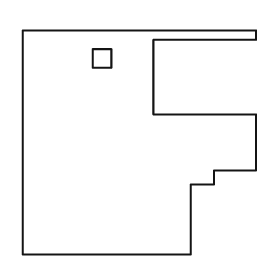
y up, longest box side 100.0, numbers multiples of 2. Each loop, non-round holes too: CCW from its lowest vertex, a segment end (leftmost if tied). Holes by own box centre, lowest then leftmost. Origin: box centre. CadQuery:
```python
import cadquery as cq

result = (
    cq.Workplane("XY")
    .moveTo(-50.0, -48.0)
    .lineTo(22.0, -48.0)
    .lineTo(22.0, -18.0)
    .lineTo(32.0, -18.0)
    .lineTo(32.0, -12.0)
    .lineTo(50.0, -12.0)
    .lineTo(50.0, 12.0)
    .lineTo(6.0, 12.0)
    .lineTo(6.0, 44.0)
    .lineTo(50.0, 44.0)
    .lineTo(50.0, 48.0)
    .lineTo(-50.0, 48.0)
    .close()
    .moveTo(-20.0, 32.0)
    .lineTo(-12.0, 32.0)
    .lineTo(-12.0, 40.0)
    .lineTo(-20.0, 40.0)
    .close()
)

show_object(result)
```